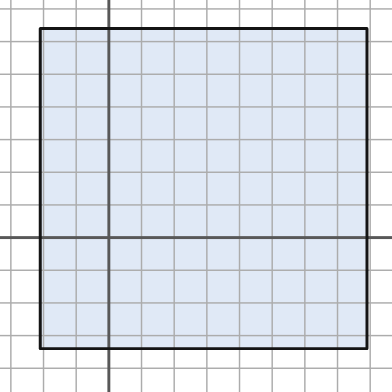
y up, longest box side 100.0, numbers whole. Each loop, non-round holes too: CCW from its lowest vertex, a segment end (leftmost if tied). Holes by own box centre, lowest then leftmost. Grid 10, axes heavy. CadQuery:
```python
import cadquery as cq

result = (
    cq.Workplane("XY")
    .moveTo(-21.0, -34.0)
    .lineTo(79.0, -34.0)
    .lineTo(79.0, 64.0)
    .lineTo(-21.0, 64.0)
    .close()
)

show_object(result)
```